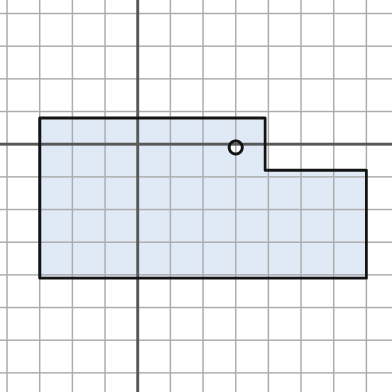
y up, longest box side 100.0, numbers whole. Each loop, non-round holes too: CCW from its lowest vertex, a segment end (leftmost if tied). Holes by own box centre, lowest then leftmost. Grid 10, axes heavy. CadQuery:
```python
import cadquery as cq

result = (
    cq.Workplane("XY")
    .moveTo(-30.0, -41.0)
    .lineTo(70.0, -41.0)
    .lineTo(70.0, -8.0)
    .lineTo(39.0, -8.0)
    .lineTo(39.0, 8.0)
    .lineTo(-30.0, 8.0)
    .close()
    .moveTo(30.0, -1.0)
    .circle(2.0)
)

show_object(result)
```